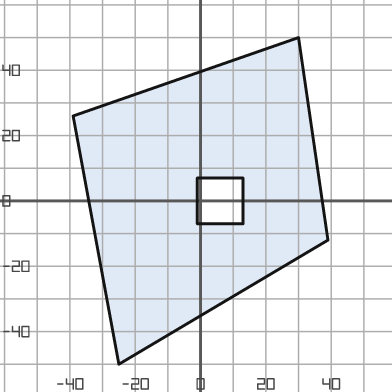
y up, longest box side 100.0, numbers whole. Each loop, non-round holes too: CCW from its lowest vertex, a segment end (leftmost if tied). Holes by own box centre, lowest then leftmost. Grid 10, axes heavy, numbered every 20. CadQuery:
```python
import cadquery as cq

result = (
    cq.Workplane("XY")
    .moveTo(-25.0, -50.0)
    .lineTo(39.0, -12.0)
    .lineTo(30.0, 50.0)
    .lineTo(-39.0, 26.0)
    .close()
    .moveTo(-1.0, -7.0)
    .lineTo(13.0, -7.0)
    .lineTo(13.0, 7.0)
    .lineTo(-1.0, 7.0)
    .close()
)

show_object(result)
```